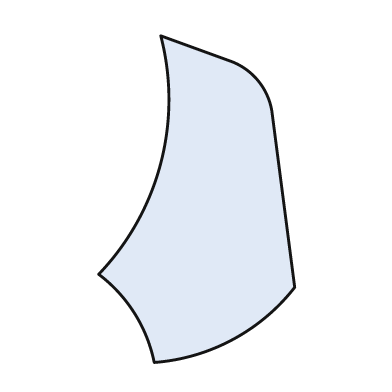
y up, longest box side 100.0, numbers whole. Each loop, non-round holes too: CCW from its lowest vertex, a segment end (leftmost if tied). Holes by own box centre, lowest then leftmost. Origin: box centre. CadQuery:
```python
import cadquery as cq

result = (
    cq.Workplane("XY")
    .moveTo(-13.0, -50.0)
    .threePointArc((11.0, -43.0), (30.0, -27.0))
    .lineTo(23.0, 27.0)
    .threePointArc((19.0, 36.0), (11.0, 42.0))
    .lineTo(-11.0, 50.0)
    .threePointArc((-11.0, 11.0), (-30.0, -23.0))
    .threePointArc((-19.0, -35.0), (-13.0, -50.0))
    .close()
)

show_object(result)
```